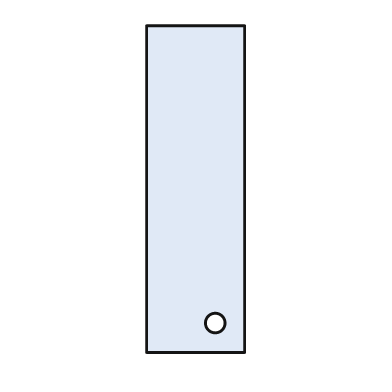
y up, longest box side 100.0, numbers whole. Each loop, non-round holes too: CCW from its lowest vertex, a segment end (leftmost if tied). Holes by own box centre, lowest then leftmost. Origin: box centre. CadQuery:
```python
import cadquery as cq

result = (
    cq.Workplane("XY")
    .moveTo(-15.0, -50.0)
    .lineTo(15.0, -50.0)
    .lineTo(15.0, 50.0)
    .lineTo(-15.0, 50.0)
    .close()
    .moveTo(6.0, -41.0)
    .circle(3.0)
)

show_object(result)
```